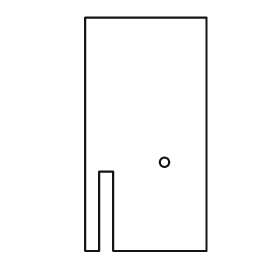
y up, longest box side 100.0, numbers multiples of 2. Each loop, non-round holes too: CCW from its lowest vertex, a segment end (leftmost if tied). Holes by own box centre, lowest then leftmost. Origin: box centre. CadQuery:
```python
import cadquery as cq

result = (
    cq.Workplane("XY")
    .moveTo(-26.0, -50.0)
    .lineTo(-20.0, -50.0)
    .lineTo(-20.0, -16.0)
    .lineTo(-14.0, -16.0)
    .lineTo(-14.0, -50.0)
    .lineTo(26.0, -50.0)
    .lineTo(26.0, 50.0)
    .lineTo(-26.0, 50.0)
    .close()
    .moveTo(8.0, -12.0)
    .circle(2.0)
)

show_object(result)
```